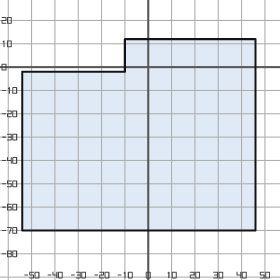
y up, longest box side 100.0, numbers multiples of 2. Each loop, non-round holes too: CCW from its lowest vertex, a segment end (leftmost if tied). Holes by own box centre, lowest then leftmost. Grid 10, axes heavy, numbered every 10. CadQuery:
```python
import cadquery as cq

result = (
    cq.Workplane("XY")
    .moveTo(-54.0, -70.0)
    .lineTo(46.0, -70.0)
    .lineTo(46.0, 12.0)
    .lineTo(-10.0, 12.0)
    .lineTo(-10.0, -2.0)
    .lineTo(-54.0, -2.0)
    .close()
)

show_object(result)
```